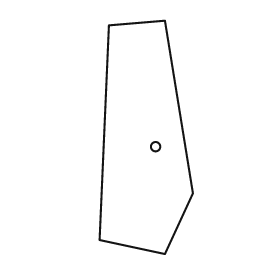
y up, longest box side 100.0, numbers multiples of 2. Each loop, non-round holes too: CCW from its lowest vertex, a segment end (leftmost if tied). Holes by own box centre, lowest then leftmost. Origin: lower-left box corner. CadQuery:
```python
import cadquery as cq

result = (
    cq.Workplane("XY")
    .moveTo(28.0, 0.0)
    .lineTo(40.0, 26.0)
    .lineTo(28.0, 100.0)
    .lineTo(4.0, 98.0)
    .lineTo(0.0, 6.0)
    .close()
    .moveTo(24.0, 46.0)
    .circle(2.0)
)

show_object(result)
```